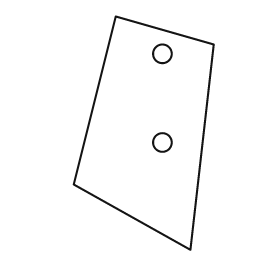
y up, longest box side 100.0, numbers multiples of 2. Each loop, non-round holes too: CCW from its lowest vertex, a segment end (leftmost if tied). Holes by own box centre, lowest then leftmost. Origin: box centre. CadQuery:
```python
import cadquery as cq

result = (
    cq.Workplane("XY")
    .moveTo(20.0, -50.0)
    .lineTo(30.0, 38.0)
    .lineTo(-12.0, 50.0)
    .lineTo(-30.0, -22.0)
    .close()
    .moveTo(8.0, -4.0)
    .circle(4.0)
    .moveTo(8.0, 34.0)
    .circle(4.0)
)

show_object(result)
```